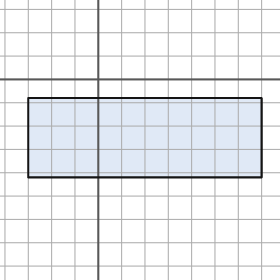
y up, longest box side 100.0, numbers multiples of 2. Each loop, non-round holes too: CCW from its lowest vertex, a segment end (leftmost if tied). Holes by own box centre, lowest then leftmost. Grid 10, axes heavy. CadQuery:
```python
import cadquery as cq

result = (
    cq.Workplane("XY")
    .moveTo(-30.0, -42.0)
    .lineTo(70.0, -42.0)
    .lineTo(70.0, -8.0)
    .lineTo(-30.0, -8.0)
    .close()
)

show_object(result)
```